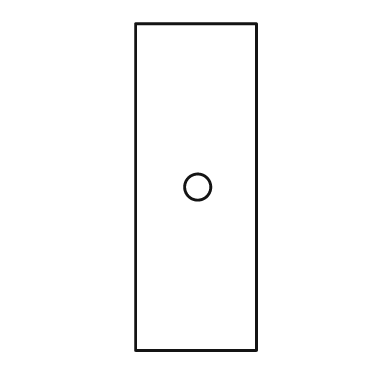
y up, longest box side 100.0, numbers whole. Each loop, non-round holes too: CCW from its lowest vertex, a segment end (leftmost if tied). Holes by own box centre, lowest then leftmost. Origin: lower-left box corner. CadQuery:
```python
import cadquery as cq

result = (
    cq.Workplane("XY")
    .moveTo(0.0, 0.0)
    .lineTo(37.0, 0.0)
    .lineTo(37.0, 100.0)
    .lineTo(0.0, 100.0)
    .close()
    .moveTo(19.0, 50.0)
    .circle(4.0)
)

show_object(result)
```